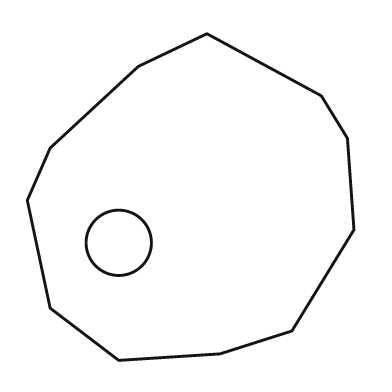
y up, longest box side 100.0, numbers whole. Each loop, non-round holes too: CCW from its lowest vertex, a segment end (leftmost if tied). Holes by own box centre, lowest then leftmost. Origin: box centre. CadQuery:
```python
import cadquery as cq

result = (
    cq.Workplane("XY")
    .moveTo(-22.0, -50.0)
    .lineTo(9.0, -48.0)
    .lineTo(31.0, -41.0)
    .lineTo(50.0, -10.0)
    .lineTo(48.0, 18.0)
    .lineTo(40.0, 31.0)
    .lineTo(5.0, 50.0)
    .lineTo(-16.0, 40.0)
    .lineTo(-43.0, 15.0)
    .lineTo(-50.0, -1.0)
    .lineTo(-43.0, -34.0)
    .close()
    .moveTo(-22.0, -14.0)
    .circle(10.0)
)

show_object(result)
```